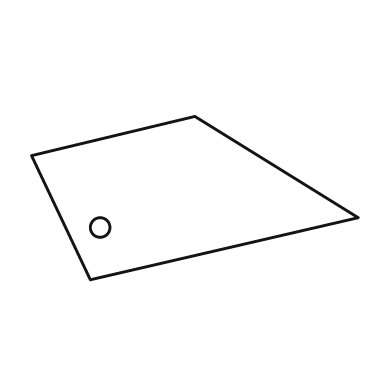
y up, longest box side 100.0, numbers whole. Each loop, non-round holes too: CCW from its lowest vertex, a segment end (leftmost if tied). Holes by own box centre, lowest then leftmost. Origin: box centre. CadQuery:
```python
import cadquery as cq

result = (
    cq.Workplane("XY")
    .moveTo(-32.0, -25.0)
    .lineTo(50.0, -6.0)
    .lineTo(0.0, 25.0)
    .lineTo(-50.0, 13.0)
    .close()
    .moveTo(-29.0, -9.0)
    .circle(3.0)
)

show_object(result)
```